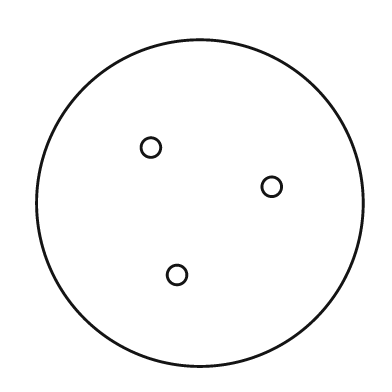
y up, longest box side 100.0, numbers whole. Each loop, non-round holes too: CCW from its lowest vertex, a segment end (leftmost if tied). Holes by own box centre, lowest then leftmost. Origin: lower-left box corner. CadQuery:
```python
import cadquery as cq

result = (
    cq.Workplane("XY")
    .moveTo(50.0, 50.0)
    .circle(50.0)
    .moveTo(43.0, 28.0)
    .circle(3.0)
    .moveTo(72.0, 55.0)
    .circle(3.0)
    .moveTo(35.0, 67.0)
    .circle(3.0)
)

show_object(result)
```